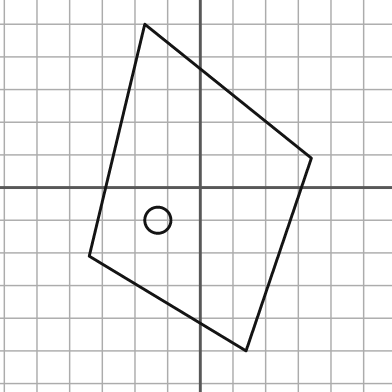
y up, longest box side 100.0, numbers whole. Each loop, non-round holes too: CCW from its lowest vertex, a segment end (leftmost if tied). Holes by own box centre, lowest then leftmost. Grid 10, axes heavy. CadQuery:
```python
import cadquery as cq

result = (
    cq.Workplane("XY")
    .moveTo(14.0, -50.0)
    .lineTo(34.0, 9.0)
    .lineTo(-17.0, 50.0)
    .lineTo(-34.0, -21.0)
    .close()
    .moveTo(-13.0, -10.0)
    .circle(4.0)
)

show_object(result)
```